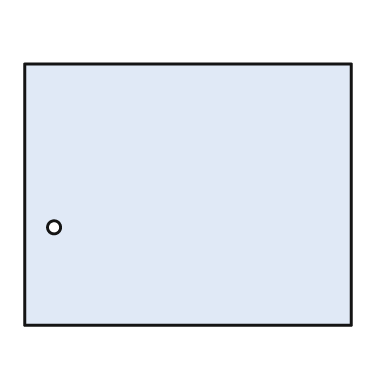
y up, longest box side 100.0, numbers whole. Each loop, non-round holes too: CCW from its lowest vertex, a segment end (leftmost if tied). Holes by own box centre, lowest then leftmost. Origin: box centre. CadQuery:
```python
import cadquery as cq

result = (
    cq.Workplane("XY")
    .moveTo(-50.0, -40.0)
    .lineTo(50.0, -40.0)
    .lineTo(50.0, 40.0)
    .lineTo(-50.0, 40.0)
    .close()
    .moveTo(-41.0, -10.0)
    .circle(2.0)
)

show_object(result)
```